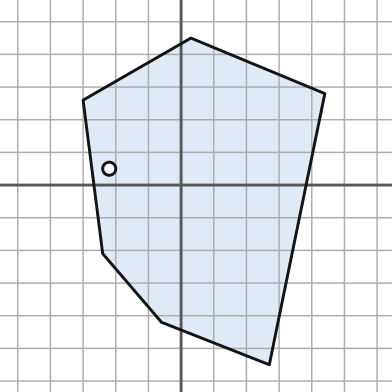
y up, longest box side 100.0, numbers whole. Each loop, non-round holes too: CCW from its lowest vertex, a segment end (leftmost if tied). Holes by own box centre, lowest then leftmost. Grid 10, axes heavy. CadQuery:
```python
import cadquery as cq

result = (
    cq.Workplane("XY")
    .moveTo(27.0, -55.0)
    .lineTo(44.0, 28.0)
    .lineTo(3.0, 45.0)
    .lineTo(-30.0, 26.0)
    .lineTo(-24.0, -21.0)
    .lineTo(-6.0, -42.0)
    .close()
    .moveTo(-22.0, 5.0)
    .circle(2.0)
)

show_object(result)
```